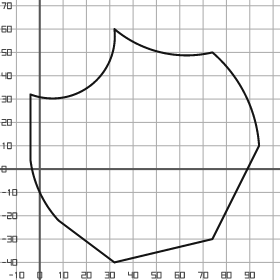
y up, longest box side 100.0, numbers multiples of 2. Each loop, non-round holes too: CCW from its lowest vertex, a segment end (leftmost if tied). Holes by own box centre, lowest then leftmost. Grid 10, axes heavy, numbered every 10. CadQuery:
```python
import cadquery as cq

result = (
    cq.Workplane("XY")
    .moveTo(32.0, -40.0)
    .lineTo(74.0, -30.0)
    .lineTo(94.0, 10.0)
    .threePointArc((88.0, 32.0), (74.0, 50.0))
    .threePointArc((52.0, 50.0), (32.0, 60.0))
    .threePointArc((22.0, 36.0), (-4.0, 32.0))
    .lineTo(-4.0, 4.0)
    .threePointArc((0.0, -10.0), (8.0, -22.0))
    .close()
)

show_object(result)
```